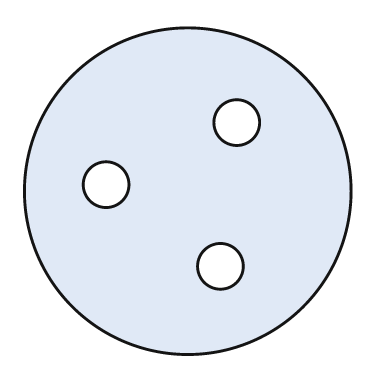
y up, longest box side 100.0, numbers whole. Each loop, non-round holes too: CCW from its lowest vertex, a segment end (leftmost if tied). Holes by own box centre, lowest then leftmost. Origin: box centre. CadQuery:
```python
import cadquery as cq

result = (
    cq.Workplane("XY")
    .moveTo(0.0, 0.0)
    .circle(50.0)
    .moveTo(10.0, -23.0)
    .circle(7.0)
    .moveTo(-25.0, 2.0)
    .circle(7.0)
    .moveTo(15.0, 21.0)
    .circle(7.0)
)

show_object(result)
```